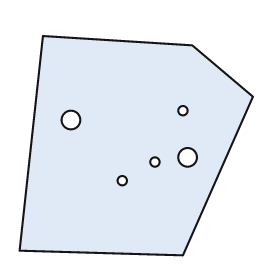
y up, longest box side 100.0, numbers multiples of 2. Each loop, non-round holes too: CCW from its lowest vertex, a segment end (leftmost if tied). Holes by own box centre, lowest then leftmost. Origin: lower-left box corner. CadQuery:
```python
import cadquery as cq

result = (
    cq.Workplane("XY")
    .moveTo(70.0, 0.0)
    .lineTo(100.0, 68.0)
    .lineTo(74.0, 90.0)
    .lineTo(10.0, 94.0)
    .lineTo(0.0, 2.0)
    .close()
    .moveTo(44.0, 32.0)
    .circle(2.0)
    .moveTo(58.0, 40.0)
    .circle(2.0)
    .moveTo(72.0, 42.0)
    .circle(4.0)
    .moveTo(22.0, 58.0)
    .circle(4.0)
    .moveTo(70.0, 62.0)
    .circle(2.0)
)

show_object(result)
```